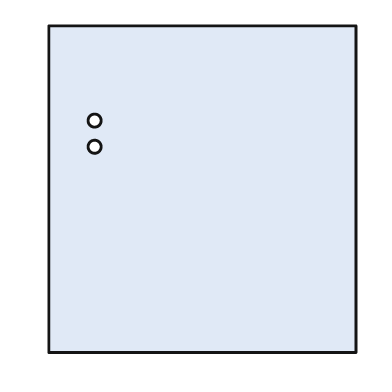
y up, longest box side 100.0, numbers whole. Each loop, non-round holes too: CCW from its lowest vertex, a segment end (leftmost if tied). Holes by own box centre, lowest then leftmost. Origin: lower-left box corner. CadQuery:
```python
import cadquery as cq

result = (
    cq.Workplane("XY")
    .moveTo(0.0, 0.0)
    .lineTo(94.0, 0.0)
    .lineTo(94.0, 100.0)
    .lineTo(0.0, 100.0)
    .close()
    .moveTo(14.0, 63.0)
    .circle(2.0)
    .moveTo(14.0, 71.0)
    .circle(2.0)
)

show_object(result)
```